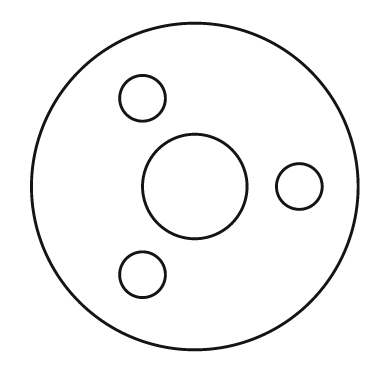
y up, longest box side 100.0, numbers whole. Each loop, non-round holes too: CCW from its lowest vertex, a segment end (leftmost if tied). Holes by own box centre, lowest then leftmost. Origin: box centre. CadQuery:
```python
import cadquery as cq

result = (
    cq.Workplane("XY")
    .moveTo(0.0, 0.0)
    .circle(50.0)
    .moveTo(-16.0, -27.0)
    .circle(7.0)
    .moveTo(0.0, 0.0)
    .circle(16.0)
    .moveTo(32.0, 0.0)
    .circle(7.0)
    .moveTo(-16.0, 27.0)
    .circle(7.0)
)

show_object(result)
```